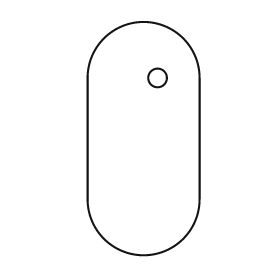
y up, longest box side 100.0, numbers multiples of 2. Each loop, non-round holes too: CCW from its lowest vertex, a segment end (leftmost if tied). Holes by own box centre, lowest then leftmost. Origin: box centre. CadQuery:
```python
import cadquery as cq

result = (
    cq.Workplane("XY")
    .moveTo(-24.0, -26.0)
    .threePointArc((0.0, -50.0), (24.0, -26.0))
    .lineTo(24.0, 26.0)
    .threePointArc((0.0, 50.0), (-24.0, 26.0))
    .close()
    .moveTo(6.0, 26.0)
    .circle(4.0)
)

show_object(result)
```